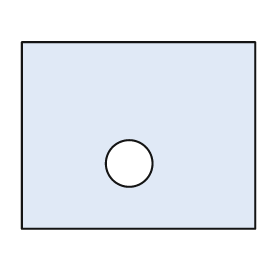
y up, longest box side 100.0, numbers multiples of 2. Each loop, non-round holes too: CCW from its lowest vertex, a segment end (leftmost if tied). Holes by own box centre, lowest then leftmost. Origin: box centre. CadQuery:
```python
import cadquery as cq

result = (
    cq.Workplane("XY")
    .moveTo(-50.0, -40.0)
    .lineTo(50.0, -40.0)
    .lineTo(50.0, 40.0)
    .lineTo(-50.0, 40.0)
    .close()
    .moveTo(-4.0, -12.0)
    .circle(10.0)
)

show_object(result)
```